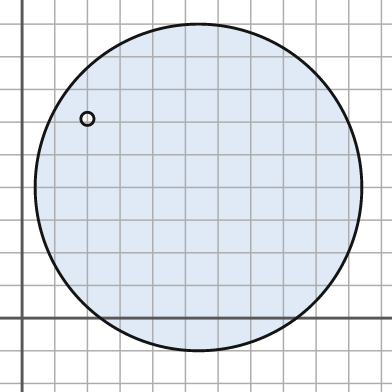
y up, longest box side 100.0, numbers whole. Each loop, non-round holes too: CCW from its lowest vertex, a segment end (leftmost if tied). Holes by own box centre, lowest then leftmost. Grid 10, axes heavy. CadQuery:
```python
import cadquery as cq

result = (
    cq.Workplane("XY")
    .moveTo(54.0, 40.0)
    .circle(50.0)
    .moveTo(20.0, 61.0)
    .circle(2.0)
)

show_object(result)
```